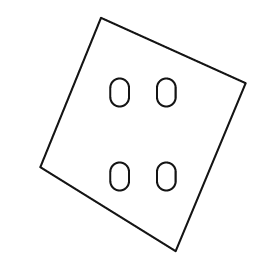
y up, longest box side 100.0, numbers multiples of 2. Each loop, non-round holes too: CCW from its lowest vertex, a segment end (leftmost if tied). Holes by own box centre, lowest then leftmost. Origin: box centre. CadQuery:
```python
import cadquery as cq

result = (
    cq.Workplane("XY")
    .moveTo(14.0, -50.0)
    .lineTo(44.0, 22.0)
    .lineTo(-18.0, 50.0)
    .lineTo(-44.0, -14.0)
    .close()
    .moveTo(-14.0, -20.0)
    .threePointArc((-10.0, -24.0), (-6.0, -20.0))
    .lineTo(-6.0, -16.0)
    .threePointArc((-10.0, -12.0), (-14.0, -16.0))
    .close()
    .moveTo(6.0, -20.0)
    .threePointArc((10.0, -24.0), (14.0, -20.0))
    .lineTo(14.0, -16.0)
    .threePointArc((10.0, -12.0), (6.0, -16.0))
    .close()
    .moveTo(-14.0, 16.0)
    .threePointArc((-10.0, 12.0), (-6.0, 16.0))
    .lineTo(-6.0, 20.0)
    .threePointArc((-10.0, 24.0), (-14.0, 20.0))
    .close()
    .moveTo(6.0, 16.0)
    .threePointArc((10.0, 12.0), (14.0, 16.0))
    .lineTo(14.0, 20.0)
    .threePointArc((10.0, 24.0), (6.0, 20.0))
    .close()
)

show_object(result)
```